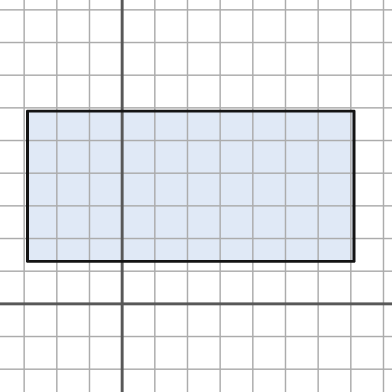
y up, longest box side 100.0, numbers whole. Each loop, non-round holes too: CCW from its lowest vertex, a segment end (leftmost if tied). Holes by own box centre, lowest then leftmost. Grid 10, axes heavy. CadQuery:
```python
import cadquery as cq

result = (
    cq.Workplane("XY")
    .moveTo(-29.0, 13.0)
    .lineTo(71.0, 13.0)
    .lineTo(71.0, 59.0)
    .lineTo(-29.0, 59.0)
    .close()
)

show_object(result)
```